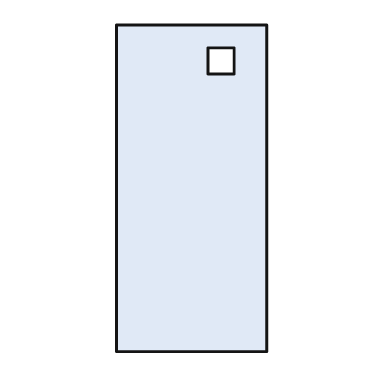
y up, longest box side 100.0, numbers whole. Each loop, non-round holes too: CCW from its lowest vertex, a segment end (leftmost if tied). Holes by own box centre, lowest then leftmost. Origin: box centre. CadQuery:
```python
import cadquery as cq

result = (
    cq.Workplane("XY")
    .moveTo(-23.0, -50.0)
    .lineTo(23.0, -50.0)
    .lineTo(23.0, 50.0)
    .lineTo(-23.0, 50.0)
    .close()
    .moveTo(5.0, 35.0)
    .lineTo(13.0, 35.0)
    .lineTo(13.0, 43.0)
    .lineTo(5.0, 43.0)
    .close()
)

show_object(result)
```